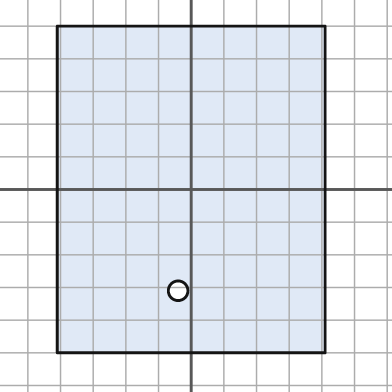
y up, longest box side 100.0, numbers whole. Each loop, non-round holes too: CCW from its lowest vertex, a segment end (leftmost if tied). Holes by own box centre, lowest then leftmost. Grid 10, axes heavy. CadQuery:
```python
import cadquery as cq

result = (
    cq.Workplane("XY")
    .moveTo(-41.0, -50.0)
    .lineTo(41.0, -50.0)
    .lineTo(41.0, 50.0)
    .lineTo(-41.0, 50.0)
    .close()
    .moveTo(-4.0, -31.0)
    .circle(3.0)
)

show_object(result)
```